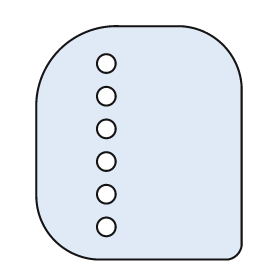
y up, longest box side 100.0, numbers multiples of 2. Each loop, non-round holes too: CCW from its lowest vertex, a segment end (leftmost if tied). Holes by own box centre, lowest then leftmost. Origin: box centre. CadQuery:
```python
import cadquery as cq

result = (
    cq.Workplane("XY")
    .moveTo(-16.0, -50.0)
    .lineTo(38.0, -50.0)
    .threePointArc((42.0, -48.0), (44.0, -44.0))
    .lineTo(44.0, 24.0)
    .threePointArc((36.0, 42.0), (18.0, 50.0))
    .lineTo(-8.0, 50.0)
    .threePointArc((-34.0, 40.0), (-44.0, 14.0))
    .lineTo(-44.0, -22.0)
    .threePointArc((-36.0, -42.0), (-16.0, -50.0))
    .close()
    .moveTo(-14.0, -36.0)
    .circle(4.0)
    .moveTo(-14.0, -22.0)
    .circle(4.0)
    .moveTo(-14.0, -8.0)
    .circle(4.0)
    .moveTo(-14.0, 6.0)
    .circle(4.0)
    .moveTo(-14.0, 20.0)
    .circle(4.0)
    .moveTo(-14.0, 34.0)
    .circle(4.0)
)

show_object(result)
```